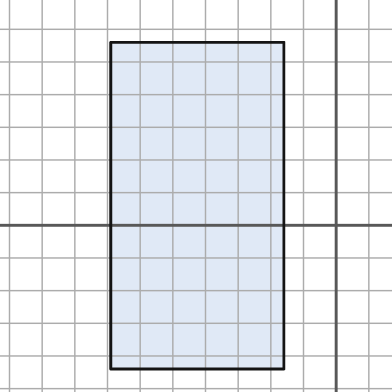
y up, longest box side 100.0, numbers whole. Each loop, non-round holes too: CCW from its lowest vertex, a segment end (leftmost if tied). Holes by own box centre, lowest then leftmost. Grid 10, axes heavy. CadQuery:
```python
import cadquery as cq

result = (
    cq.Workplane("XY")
    .moveTo(-69.0, -44.0)
    .lineTo(-16.0, -44.0)
    .lineTo(-16.0, 56.0)
    .lineTo(-69.0, 56.0)
    .close()
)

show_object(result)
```